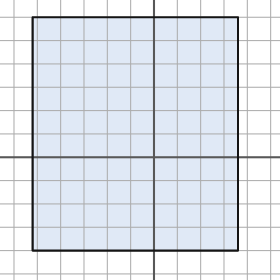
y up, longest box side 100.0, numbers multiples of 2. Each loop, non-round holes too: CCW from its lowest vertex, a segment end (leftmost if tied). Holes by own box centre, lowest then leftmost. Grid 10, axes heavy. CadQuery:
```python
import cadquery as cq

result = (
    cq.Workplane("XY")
    .moveTo(-52.0, -40.0)
    .lineTo(36.0, -40.0)
    .lineTo(36.0, 60.0)
    .lineTo(-52.0, 60.0)
    .close()
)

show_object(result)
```